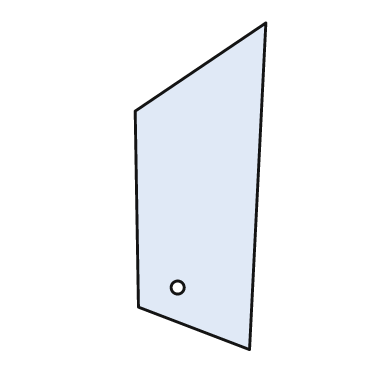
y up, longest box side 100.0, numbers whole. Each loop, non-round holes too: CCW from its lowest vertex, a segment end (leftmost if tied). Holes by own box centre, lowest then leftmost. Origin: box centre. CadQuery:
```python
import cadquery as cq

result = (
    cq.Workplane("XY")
    .moveTo(15.0, -50.0)
    .lineTo(20.0, 50.0)
    .lineTo(-20.0, 23.0)
    .lineTo(-19.0, -37.0)
    .close()
    .moveTo(-7.0, -31.0)
    .circle(2.0)
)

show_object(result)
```